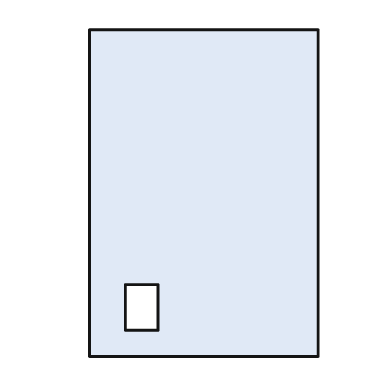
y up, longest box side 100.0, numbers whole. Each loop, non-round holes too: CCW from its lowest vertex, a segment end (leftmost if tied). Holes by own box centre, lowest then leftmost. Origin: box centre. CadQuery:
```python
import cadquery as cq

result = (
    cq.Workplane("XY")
    .moveTo(-35.0, -50.0)
    .lineTo(35.0, -50.0)
    .lineTo(35.0, 50.0)
    .lineTo(-35.0, 50.0)
    .close()
    .moveTo(-24.0, -42.0)
    .lineTo(-14.0, -42.0)
    .lineTo(-14.0, -28.0)
    .lineTo(-24.0, -28.0)
    .close()
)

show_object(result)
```